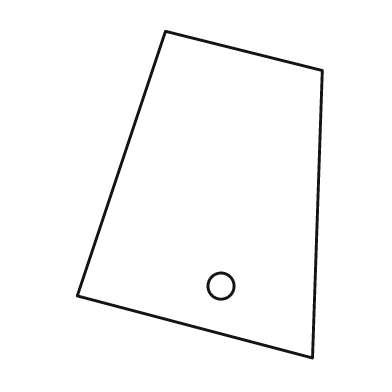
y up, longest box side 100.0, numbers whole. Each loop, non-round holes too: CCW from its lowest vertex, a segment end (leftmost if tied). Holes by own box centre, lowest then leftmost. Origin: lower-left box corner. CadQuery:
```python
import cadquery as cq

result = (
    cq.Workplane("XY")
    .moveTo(72.0, 0.0)
    .lineTo(75.0, 88.0)
    .lineTo(27.0, 100.0)
    .lineTo(0.0, 19.0)
    .close()
    .moveTo(44.0, 22.0)
    .circle(4.0)
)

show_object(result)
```